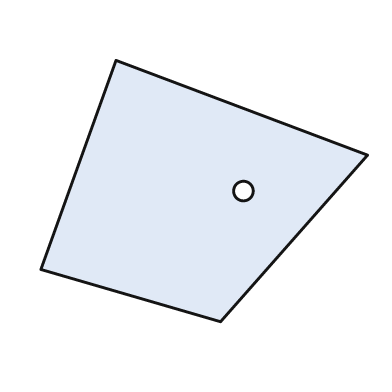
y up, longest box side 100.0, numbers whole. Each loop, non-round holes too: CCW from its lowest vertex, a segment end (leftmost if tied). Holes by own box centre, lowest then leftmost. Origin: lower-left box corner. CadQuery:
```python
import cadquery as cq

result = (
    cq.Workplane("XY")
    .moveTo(55.0, 0.0)
    .lineTo(100.0, 51.0)
    .lineTo(23.0, 80.0)
    .lineTo(0.0, 16.0)
    .close()
    .moveTo(62.0, 40.0)
    .circle(3.0)
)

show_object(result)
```